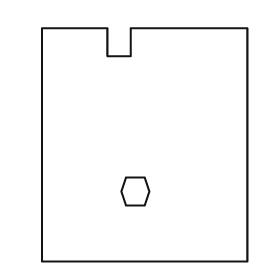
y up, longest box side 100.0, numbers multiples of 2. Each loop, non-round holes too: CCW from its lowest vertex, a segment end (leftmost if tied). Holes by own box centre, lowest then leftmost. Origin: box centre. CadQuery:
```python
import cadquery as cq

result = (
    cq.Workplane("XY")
    .moveTo(-44.0, -50.0)
    .lineTo(44.0, -50.0)
    .lineTo(44.0, 50.0)
    .lineTo(-6.0, 50.0)
    .lineTo(-6.0, 38.0)
    .lineTo(-16.0, 38.0)
    .lineTo(-16.0, 50.0)
    .lineTo(-44.0, 50.0)
    .close()
    .moveTo(-8.0, -26.0)
    .lineTo(0.0, -26.0)
    .lineTo(2.0, -20.0)
    .lineTo(0.0, -14.0)
    .lineTo(-8.0, -14.0)
    .lineTo(-10.0, -20.0)
    .close()
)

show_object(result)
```